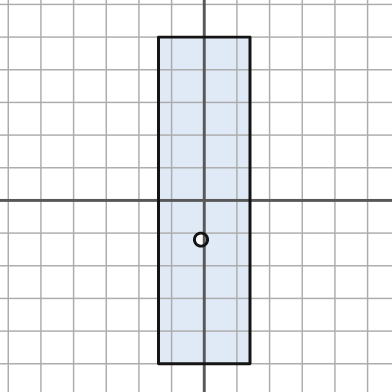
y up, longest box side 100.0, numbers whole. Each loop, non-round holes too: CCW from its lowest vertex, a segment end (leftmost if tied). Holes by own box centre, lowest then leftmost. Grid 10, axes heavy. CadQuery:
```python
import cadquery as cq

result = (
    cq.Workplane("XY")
    .moveTo(-14.0, -50.0)
    .lineTo(14.0, -50.0)
    .lineTo(14.0, 50.0)
    .lineTo(-14.0, 50.0)
    .close()
    .moveTo(-1.0, -12.0)
    .circle(2.0)
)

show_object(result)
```